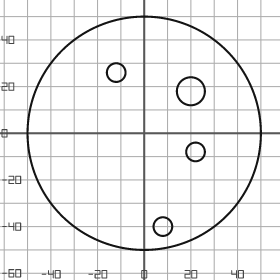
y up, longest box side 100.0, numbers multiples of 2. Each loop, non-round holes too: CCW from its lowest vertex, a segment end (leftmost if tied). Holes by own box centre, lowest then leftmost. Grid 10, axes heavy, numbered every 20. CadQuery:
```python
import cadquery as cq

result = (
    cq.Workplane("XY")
    .moveTo(0.0, 0.0)
    .circle(50.0)
    .moveTo(8.0, -40.0)
    .circle(4.0)
    .moveTo(22.0, -8.0)
    .circle(4.0)
    .moveTo(20.0, 18.0)
    .circle(6.0)
    .moveTo(-12.0, 26.0)
    .circle(4.0)
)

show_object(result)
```